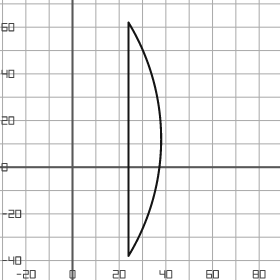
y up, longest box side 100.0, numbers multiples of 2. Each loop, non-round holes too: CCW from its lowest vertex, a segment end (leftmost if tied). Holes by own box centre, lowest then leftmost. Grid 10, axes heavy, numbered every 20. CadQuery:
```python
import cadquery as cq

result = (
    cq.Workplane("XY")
    .moveTo(24.0, -38.0)
    .threePointArc((38.0, 12.0), (24.0, 62.0))
    .close()
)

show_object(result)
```